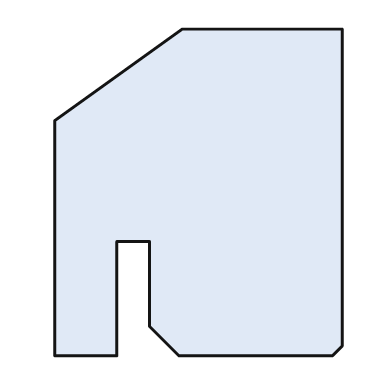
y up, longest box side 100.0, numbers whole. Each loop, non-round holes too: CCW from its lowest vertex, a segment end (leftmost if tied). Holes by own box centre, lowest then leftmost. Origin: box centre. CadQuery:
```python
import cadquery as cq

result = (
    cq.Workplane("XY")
    .moveTo(-44.0, -50.0)
    .lineTo(-25.0, -50.0)
    .lineTo(-25.0, -15.0)
    .lineTo(-15.0, -15.0)
    .lineTo(-15.0, -41.0)
    .lineTo(-6.0, -50.0)
    .lineTo(41.0, -50.0)
    .lineTo(44.0, -47.0)
    .lineTo(44.0, 50.0)
    .lineTo(-5.0, 50.0)
    .lineTo(-44.0, 22.0)
    .close()
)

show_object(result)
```